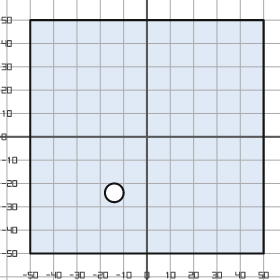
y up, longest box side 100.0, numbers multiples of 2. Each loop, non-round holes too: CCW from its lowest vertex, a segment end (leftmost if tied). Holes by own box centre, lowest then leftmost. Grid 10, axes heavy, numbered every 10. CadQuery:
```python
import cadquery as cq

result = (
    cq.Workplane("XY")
    .moveTo(-50.0, -50.0)
    .lineTo(50.0, -50.0)
    .lineTo(50.0, 50.0)
    .lineTo(-50.0, 50.0)
    .close()
    .moveTo(-14.0, -24.0)
    .circle(4.0)
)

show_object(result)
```